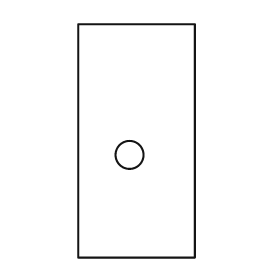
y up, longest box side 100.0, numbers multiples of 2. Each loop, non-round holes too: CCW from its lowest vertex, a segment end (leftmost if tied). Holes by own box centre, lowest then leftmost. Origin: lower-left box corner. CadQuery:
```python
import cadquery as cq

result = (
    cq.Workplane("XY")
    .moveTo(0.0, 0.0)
    .lineTo(50.0, 0.0)
    .lineTo(50.0, 100.0)
    .lineTo(0.0, 100.0)
    .close()
    .moveTo(22.0, 44.0)
    .circle(6.0)
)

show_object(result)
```